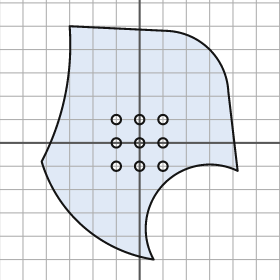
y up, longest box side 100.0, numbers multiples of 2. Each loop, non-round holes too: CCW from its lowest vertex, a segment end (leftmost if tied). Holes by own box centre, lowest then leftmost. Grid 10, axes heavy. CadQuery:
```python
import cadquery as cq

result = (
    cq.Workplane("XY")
    .moveTo(6.0, -50.0)
    .threePointArc((10.0, -18.0), (42.0, -12.0))
    .lineTo(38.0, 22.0)
    .threePointArc((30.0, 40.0), (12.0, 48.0))
    .lineTo(-30.0, 50.0)
    .threePointArc((-32.0, 20.0), (-42.0, -8.0))
    .threePointArc((-24.0, -36.0), (6.0, -50.0))
    .close()
    .moveTo(-10.0, -10.0)
    .circle(2.0)
    .moveTo(0.0, -10.0)
    .circle(2.0)
    .moveTo(10.0, -10.0)
    .circle(2.0)
    .moveTo(-10.0, 0.0)
    .circle(2.0)
    .moveTo(0.0, 0.0)
    .circle(2.0)
    .moveTo(10.0, 0.0)
    .circle(2.0)
    .moveTo(-10.0, 10.0)
    .circle(2.0)
    .moveTo(0.0, 10.0)
    .circle(2.0)
    .moveTo(10.0, 10.0)
    .circle(2.0)
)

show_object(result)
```